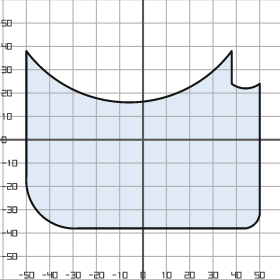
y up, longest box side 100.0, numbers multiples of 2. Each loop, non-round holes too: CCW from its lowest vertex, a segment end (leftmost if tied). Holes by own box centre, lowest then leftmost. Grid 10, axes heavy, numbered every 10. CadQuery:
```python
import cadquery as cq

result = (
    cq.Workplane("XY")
    .moveTo(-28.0, -38.0)
    .lineTo(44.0, -38.0)
    .threePointArc((48.0, -36.0), (50.0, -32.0))
    .lineTo(50.0, 24.0)
    .threePointArc((44.0, 22.0), (38.0, 24.0))
    .lineTo(38.0, 38.0)
    .threePointArc((-6.0, 16.0), (-50.0, 38.0))
    .lineTo(-50.0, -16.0)
    .threePointArc((-44.0, -32.0), (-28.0, -38.0))
    .close()
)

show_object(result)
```